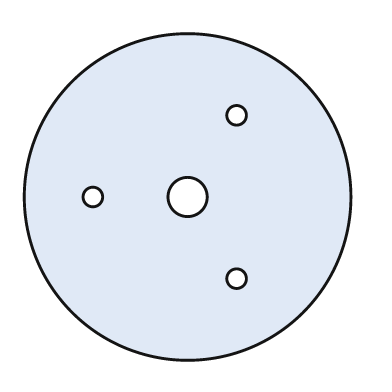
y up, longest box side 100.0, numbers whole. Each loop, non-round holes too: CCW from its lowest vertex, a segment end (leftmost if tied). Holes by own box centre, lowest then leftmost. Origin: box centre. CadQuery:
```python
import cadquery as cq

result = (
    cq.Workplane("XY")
    .moveTo(0.0, 0.0)
    .circle(50.0)
    .moveTo(15.0, -25.0)
    .circle(3.0)
    .moveTo(-29.0, 0.0)
    .circle(3.0)
    .moveTo(0.0, 0.0)
    .circle(6.0)
    .moveTo(15.0, 25.0)
    .circle(3.0)
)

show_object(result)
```